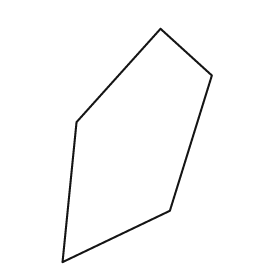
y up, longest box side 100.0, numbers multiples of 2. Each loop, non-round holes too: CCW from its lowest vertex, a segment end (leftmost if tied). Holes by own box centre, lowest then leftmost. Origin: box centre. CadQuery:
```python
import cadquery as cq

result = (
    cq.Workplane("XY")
    .moveTo(-32.0, -50.0)
    .lineTo(14.0, -28.0)
    .lineTo(32.0, 30.0)
    .lineTo(10.0, 50.0)
    .lineTo(-26.0, 10.0)
    .close()
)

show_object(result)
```